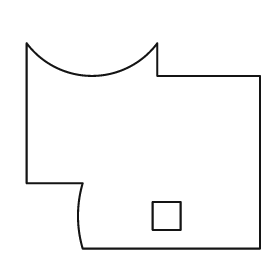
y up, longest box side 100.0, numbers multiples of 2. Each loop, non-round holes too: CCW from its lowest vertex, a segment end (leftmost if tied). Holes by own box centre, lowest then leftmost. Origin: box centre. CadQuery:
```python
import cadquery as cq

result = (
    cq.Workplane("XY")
    .moveTo(-26.0, -44.0)
    .lineTo(50.0, -44.0)
    .lineTo(50.0, 30.0)
    .lineTo(6.0, 30.0)
    .lineTo(6.0, 44.0)
    .threePointArc((-22.0, 30.0), (-50.0, 44.0))
    .lineTo(-50.0, -16.0)
    .lineTo(-26.0, -16.0)
    .threePointArc((-28.0, -30.0), (-26.0, -44.0))
    .close()
    .moveTo(4.0, -36.0)
    .lineTo(16.0, -36.0)
    .lineTo(16.0, -24.0)
    .lineTo(4.0, -24.0)
    .close()
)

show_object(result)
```